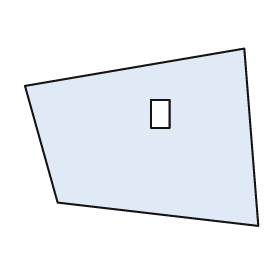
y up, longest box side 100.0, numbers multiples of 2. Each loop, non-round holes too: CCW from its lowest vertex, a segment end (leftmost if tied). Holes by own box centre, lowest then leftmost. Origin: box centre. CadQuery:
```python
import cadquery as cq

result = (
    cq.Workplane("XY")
    .moveTo(50.0, -38.0)
    .lineTo(44.0, 38.0)
    .lineTo(-50.0, 22.0)
    .lineTo(-36.0, -28.0)
    .close()
    .moveTo(4.0, 4.0)
    .lineTo(12.0, 4.0)
    .lineTo(12.0, 16.0)
    .lineTo(4.0, 16.0)
    .close()
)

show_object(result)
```